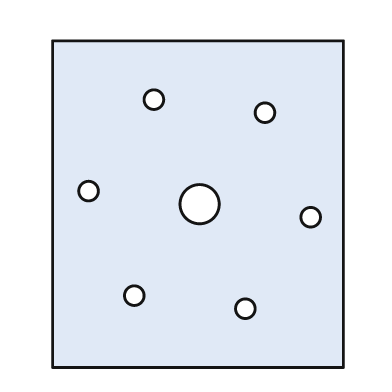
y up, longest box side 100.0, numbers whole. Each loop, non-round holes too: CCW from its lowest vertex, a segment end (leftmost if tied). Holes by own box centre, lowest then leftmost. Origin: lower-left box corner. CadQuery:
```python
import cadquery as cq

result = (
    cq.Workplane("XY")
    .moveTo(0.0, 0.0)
    .lineTo(89.0, 0.0)
    .lineTo(89.0, 100.0)
    .lineTo(0.0, 100.0)
    .close()
    .moveTo(59.0, 18.0)
    .circle(3.0)
    .moveTo(25.0, 22.0)
    .circle(3.0)
    .moveTo(79.0, 46.0)
    .circle(3.0)
    .moveTo(45.0, 50.0)
    .circle(6.0)
    .moveTo(11.0, 54.0)
    .circle(3.0)
    .moveTo(65.0, 78.0)
    .circle(3.0)
    .moveTo(31.0, 82.0)
    .circle(3.0)
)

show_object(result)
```